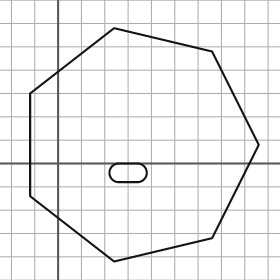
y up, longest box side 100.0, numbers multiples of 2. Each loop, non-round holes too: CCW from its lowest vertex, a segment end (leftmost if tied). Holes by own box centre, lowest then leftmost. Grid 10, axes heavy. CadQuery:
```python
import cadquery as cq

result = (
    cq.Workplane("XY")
    .moveTo(24.0, -42.0)
    .lineTo(66.0, -32.0)
    .lineTo(86.0, 8.0)
    .lineTo(66.0, 48.0)
    .lineTo(24.0, 58.0)
    .lineTo(-12.0, 30.0)
    .lineTo(-12.0, -14.0)
    .close()
    .moveTo(26.0, -8.0)
    .lineTo(34.0, -8.0)
    .threePointArc((38.0, -4.0), (34.0, 0.0))
    .lineTo(26.0, 0.0)
    .threePointArc((22.0, -4.0), (26.0, -8.0))
    .close()
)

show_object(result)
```